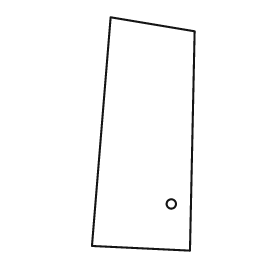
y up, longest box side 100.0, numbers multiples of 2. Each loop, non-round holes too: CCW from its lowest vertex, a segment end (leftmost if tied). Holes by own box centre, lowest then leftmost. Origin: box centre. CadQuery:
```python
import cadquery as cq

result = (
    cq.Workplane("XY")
    .moveTo(20.0, -50.0)
    .lineTo(22.0, 44.0)
    .lineTo(-14.0, 50.0)
    .lineTo(-22.0, -48.0)
    .close()
    .moveTo(12.0, -30.0)
    .circle(2.0)
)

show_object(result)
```